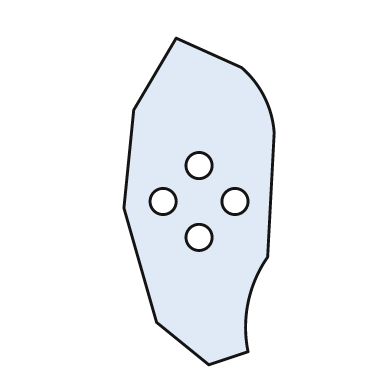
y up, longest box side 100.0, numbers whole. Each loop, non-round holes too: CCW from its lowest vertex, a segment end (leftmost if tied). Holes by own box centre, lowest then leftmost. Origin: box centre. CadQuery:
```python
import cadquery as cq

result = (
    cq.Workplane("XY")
    .moveTo(3.0, -50.0)
    .lineTo(15.0, -46.0)
    .threePointArc((15.0, -31.0), (21.0, -17.0))
    .lineTo(23.0, 21.0)
    .threePointArc((20.0, 32.0), (13.0, 41.0))
    .lineTo(-7.0, 50.0)
    .lineTo(-20.0, 28.0)
    .lineTo(-23.0, -2.0)
    .lineTo(-13.0, -37.0)
    .close()
    .moveTo(0.0, -11.0)
    .circle(4.0)
    .moveTo(-11.0, 0.0)
    .circle(4.0)
    .moveTo(11.0, 0.0)
    .circle(4.0)
    .moveTo(0.0, 11.0)
    .circle(4.0)
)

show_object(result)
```